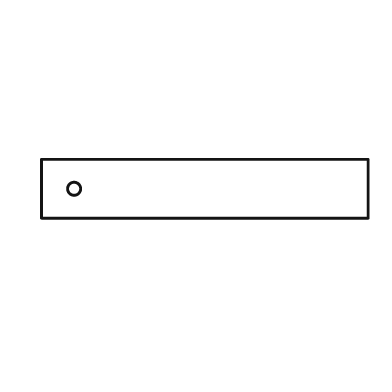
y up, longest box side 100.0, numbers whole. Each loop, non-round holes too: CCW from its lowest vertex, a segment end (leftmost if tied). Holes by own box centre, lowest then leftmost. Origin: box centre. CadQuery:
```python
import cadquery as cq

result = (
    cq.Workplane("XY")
    .moveTo(-50.0, -9.0)
    .lineTo(50.0, -9.0)
    .lineTo(50.0, 9.0)
    .lineTo(-50.0, 9.0)
    .close()
    .moveTo(-40.0, 0.0)
    .circle(2.0)
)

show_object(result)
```